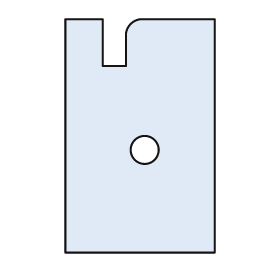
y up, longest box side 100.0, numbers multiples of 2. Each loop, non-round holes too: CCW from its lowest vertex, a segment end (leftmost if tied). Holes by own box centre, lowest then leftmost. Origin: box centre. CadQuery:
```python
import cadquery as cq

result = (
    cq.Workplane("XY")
    .moveTo(-32.0, -50.0)
    .lineTo(32.0, -50.0)
    .lineTo(32.0, 50.0)
    .lineTo(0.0, 50.0)
    .threePointArc((-4.0, 48.0), (-6.0, 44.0))
    .lineTo(-6.0, 30.0)
    .lineTo(-16.0, 30.0)
    .lineTo(-16.0, 50.0)
    .lineTo(-32.0, 50.0)
    .close()
    .moveTo(2.0, -6.0)
    .circle(6.0)
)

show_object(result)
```